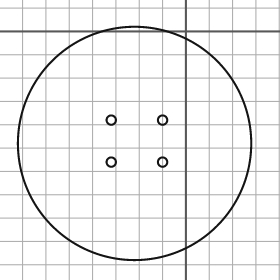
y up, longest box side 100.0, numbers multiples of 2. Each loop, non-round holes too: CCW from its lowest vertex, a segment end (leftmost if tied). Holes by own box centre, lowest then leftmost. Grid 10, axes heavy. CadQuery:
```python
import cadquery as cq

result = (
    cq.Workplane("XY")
    .moveTo(-22.0, -48.0)
    .circle(50.0)
    .moveTo(-32.0, -56.0)
    .circle(2.0)
    .moveTo(-10.0, -56.0)
    .circle(2.0)
    .moveTo(-32.0, -38.0)
    .circle(2.0)
    .moveTo(-10.0, -38.0)
    .circle(2.0)
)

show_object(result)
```